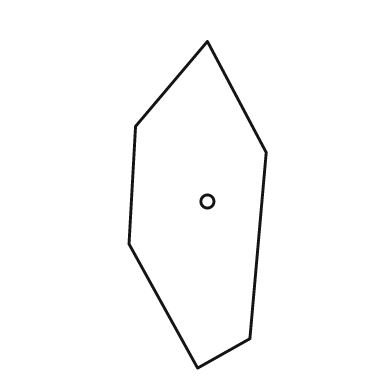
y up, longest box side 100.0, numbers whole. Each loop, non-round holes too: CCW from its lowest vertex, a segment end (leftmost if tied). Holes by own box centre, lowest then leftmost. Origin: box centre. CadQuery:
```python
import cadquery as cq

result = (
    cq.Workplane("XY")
    .moveTo(0.0, -50.0)
    .lineTo(16.0, -41.0)
    .lineTo(21.0, 16.0)
    .lineTo(3.0, 50.0)
    .lineTo(-19.0, 24.0)
    .lineTo(-21.0, -12.0)
    .close()
    .moveTo(3.0, 1.0)
    .circle(2.0)
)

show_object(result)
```